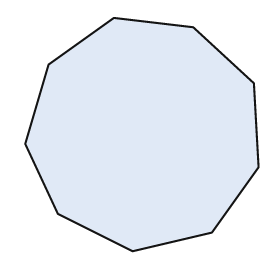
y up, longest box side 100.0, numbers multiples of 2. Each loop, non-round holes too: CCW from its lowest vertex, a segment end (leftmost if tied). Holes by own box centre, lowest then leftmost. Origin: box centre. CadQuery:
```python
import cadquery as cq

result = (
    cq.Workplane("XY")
    .moveTo(-4.0, -50.0)
    .lineTo(30.0, -42.0)
    .lineTo(50.0, -14.0)
    .lineTo(48.0, 22.0)
    .lineTo(22.0, 46.0)
    .lineTo(-12.0, 50.0)
    .lineTo(-40.0, 30.0)
    .lineTo(-50.0, -4.0)
    .lineTo(-36.0, -34.0)
    .close()
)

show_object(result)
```